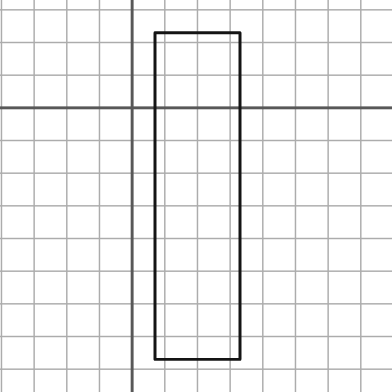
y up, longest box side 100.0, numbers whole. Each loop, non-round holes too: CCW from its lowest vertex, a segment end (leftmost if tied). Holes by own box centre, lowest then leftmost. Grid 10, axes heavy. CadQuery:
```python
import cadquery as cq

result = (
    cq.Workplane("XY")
    .moveTo(7.0, -77.0)
    .lineTo(33.0, -77.0)
    .lineTo(33.0, 23.0)
    .lineTo(7.0, 23.0)
    .close()
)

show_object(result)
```